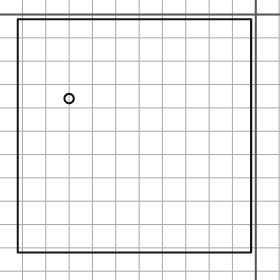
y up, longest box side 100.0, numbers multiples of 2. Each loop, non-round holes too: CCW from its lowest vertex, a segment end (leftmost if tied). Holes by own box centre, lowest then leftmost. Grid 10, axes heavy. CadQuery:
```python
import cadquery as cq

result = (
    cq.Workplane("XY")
    .moveTo(-102.0, -102.0)
    .lineTo(-2.0, -102.0)
    .lineTo(-2.0, -2.0)
    .lineTo(-102.0, -2.0)
    .close()
    .moveTo(-80.0, -36.0)
    .circle(2.0)
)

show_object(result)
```